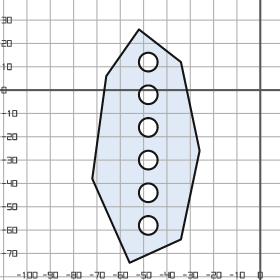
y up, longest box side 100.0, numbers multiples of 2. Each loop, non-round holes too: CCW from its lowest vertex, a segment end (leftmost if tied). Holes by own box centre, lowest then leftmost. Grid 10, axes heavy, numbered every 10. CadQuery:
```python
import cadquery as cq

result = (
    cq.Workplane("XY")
    .moveTo(-56.0, -74.0)
    .lineTo(-34.0, -64.0)
    .lineTo(-26.0, -26.0)
    .lineTo(-34.0, 12.0)
    .lineTo(-52.0, 26.0)
    .lineTo(-66.0, 6.0)
    .lineTo(-72.0, -38.0)
    .close()
    .moveTo(-48.0, -58.0)
    .circle(4.0)
    .moveTo(-48.0, -44.0)
    .circle(4.0)
    .moveTo(-48.0, -30.0)
    .circle(4.0)
    .moveTo(-48.0, -16.0)
    .circle(4.0)
    .moveTo(-48.0, -2.0)
    .circle(4.0)
    .moveTo(-48.0, 12.0)
    .circle(4.0)
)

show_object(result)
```